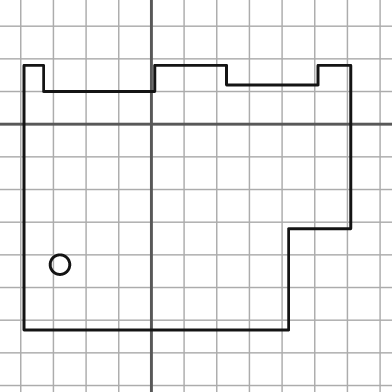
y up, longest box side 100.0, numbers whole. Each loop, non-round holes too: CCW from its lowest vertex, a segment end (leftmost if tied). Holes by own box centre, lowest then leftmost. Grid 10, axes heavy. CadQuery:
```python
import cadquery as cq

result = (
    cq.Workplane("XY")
    .moveTo(-39.0, -63.0)
    .lineTo(42.0, -63.0)
    .lineTo(42.0, -32.0)
    .lineTo(61.0, -32.0)
    .lineTo(61.0, 18.0)
    .lineTo(51.0, 18.0)
    .lineTo(51.0, 12.0)
    .lineTo(23.0, 12.0)
    .lineTo(23.0, 18.0)
    .lineTo(1.0, 18.0)
    .lineTo(1.0, 10.0)
    .lineTo(-33.0, 10.0)
    .lineTo(-33.0, 18.0)
    .lineTo(-39.0, 18.0)
    .close()
    .moveTo(-28.0, -43.0)
    .circle(3.0)
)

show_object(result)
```